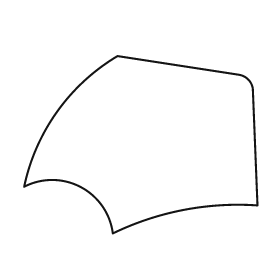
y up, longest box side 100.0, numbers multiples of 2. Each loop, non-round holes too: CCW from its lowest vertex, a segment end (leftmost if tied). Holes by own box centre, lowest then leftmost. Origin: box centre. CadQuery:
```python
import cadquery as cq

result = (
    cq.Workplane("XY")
    .moveTo(-12.0, -38.0)
    .threePointArc((18.0, -28.0), (50.0, -26.0))
    .lineTo(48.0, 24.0)
    .threePointArc((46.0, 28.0), (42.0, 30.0))
    .lineTo(-10.0, 38.0)
    .threePointArc((-36.0, 14.0), (-50.0, -18.0))
    .threePointArc((-26.0, -18.0), (-12.0, -38.0))
    .close()
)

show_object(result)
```